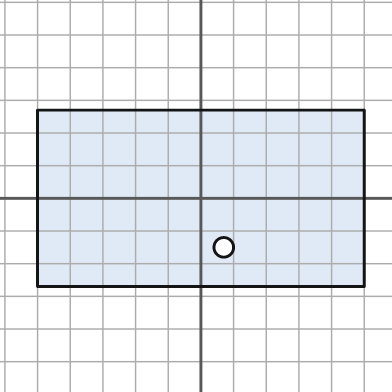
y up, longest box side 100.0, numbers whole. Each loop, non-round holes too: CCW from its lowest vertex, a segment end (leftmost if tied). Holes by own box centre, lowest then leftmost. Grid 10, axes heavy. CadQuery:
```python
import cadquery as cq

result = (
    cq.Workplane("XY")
    .moveTo(-50.0, -27.0)
    .lineTo(50.0, -27.0)
    .lineTo(50.0, 27.0)
    .lineTo(-50.0, 27.0)
    .close()
    .moveTo(7.0, -15.0)
    .circle(3.0)
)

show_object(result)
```